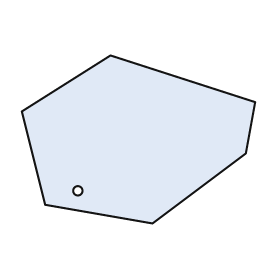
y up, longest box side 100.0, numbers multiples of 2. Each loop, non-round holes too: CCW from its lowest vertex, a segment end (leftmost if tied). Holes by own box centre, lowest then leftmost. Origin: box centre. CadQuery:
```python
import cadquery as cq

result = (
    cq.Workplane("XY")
    .moveTo(6.0, -36.0)
    .lineTo(46.0, -6.0)
    .lineTo(50.0, 16.0)
    .lineTo(-12.0, 36.0)
    .lineTo(-50.0, 12.0)
    .lineTo(-40.0, -28.0)
    .close()
    .moveTo(-26.0, -22.0)
    .circle(2.0)
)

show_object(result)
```